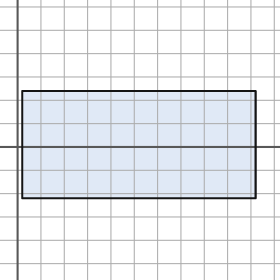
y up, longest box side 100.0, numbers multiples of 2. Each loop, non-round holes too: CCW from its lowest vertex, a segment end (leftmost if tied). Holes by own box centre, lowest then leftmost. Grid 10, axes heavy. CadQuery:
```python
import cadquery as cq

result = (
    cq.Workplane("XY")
    .moveTo(2.0, -22.0)
    .lineTo(102.0, -22.0)
    .lineTo(102.0, 24.0)
    .lineTo(2.0, 24.0)
    .close()
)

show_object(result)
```